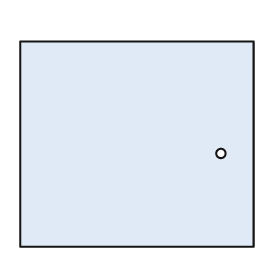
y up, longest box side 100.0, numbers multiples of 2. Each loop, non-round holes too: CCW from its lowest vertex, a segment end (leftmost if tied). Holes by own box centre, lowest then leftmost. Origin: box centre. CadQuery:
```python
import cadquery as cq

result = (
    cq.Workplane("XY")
    .moveTo(-50.0, -44.0)
    .lineTo(50.0, -44.0)
    .lineTo(50.0, 44.0)
    .lineTo(-50.0, 44.0)
    .close()
    .moveTo(36.0, -4.0)
    .circle(2.0)
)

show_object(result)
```